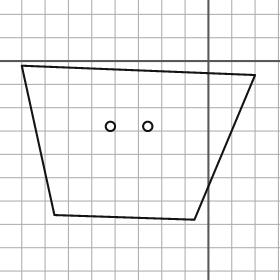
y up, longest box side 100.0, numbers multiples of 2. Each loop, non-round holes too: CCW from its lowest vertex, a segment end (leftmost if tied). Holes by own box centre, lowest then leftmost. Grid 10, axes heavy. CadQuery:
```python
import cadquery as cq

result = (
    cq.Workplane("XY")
    .moveTo(-6.0, -68.0)
    .lineTo(20.0, -6.0)
    .lineTo(-80.0, -2.0)
    .lineTo(-66.0, -66.0)
    .close()
    .moveTo(-42.0, -28.0)
    .circle(2.0)
    .moveTo(-26.0, -28.0)
    .circle(2.0)
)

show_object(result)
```